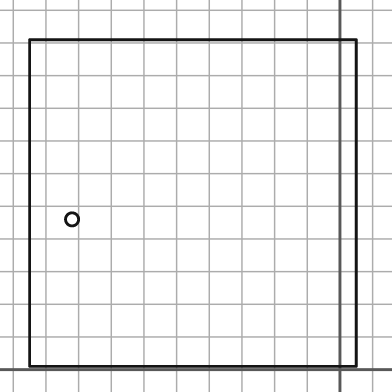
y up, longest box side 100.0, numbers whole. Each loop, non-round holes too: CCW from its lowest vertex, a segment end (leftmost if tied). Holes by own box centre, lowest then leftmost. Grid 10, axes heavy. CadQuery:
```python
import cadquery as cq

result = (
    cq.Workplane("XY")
    .moveTo(-95.0, 1.0)
    .lineTo(5.0, 1.0)
    .lineTo(5.0, 101.0)
    .lineTo(-95.0, 101.0)
    .close()
    .moveTo(-82.0, 46.0)
    .circle(2.0)
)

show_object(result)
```